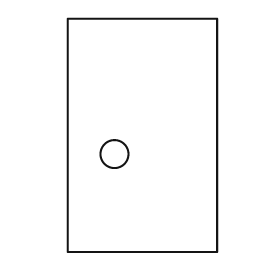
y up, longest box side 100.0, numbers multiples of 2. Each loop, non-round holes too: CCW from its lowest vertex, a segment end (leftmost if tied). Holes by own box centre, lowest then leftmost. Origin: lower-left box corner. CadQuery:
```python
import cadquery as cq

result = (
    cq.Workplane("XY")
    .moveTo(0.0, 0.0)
    .lineTo(64.0, 0.0)
    .lineTo(64.0, 100.0)
    .lineTo(0.0, 100.0)
    .close()
    .moveTo(20.0, 42.0)
    .circle(6.0)
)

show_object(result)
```